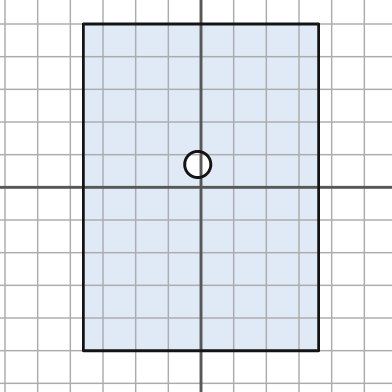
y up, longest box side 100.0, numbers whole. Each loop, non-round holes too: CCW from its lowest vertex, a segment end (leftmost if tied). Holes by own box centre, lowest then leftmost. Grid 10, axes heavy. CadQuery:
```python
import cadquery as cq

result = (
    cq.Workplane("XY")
    .moveTo(-36.0, -50.0)
    .lineTo(36.0, -50.0)
    .lineTo(36.0, 50.0)
    .lineTo(-36.0, 50.0)
    .close()
    .moveTo(-1.0, 7.0)
    .circle(4.0)
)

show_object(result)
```